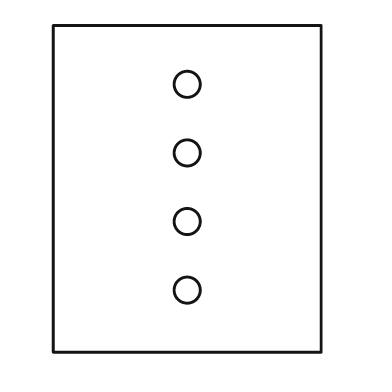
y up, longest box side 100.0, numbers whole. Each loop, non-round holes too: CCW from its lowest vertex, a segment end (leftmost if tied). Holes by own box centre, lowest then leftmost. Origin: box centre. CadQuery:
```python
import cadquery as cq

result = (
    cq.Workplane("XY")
    .moveTo(-41.0, -50.0)
    .lineTo(41.0, -50.0)
    .lineTo(41.0, 50.0)
    .lineTo(-41.0, 50.0)
    .close()
    .moveTo(0.0, -31.0)
    .circle(4.0)
    .moveTo(0.0, -10.0)
    .circle(4.0)
    .moveTo(0.0, 11.0)
    .circle(4.0)
    .moveTo(0.0, 32.0)
    .circle(4.0)
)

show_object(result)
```